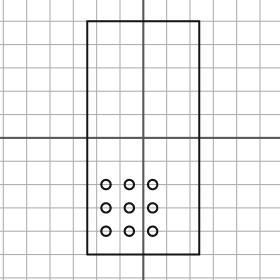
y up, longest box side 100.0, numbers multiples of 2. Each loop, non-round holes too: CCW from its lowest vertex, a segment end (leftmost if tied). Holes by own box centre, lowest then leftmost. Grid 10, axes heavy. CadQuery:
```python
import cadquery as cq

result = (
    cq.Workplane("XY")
    .moveTo(-24.0, -50.0)
    .lineTo(24.0, -50.0)
    .lineTo(24.0, 50.0)
    .lineTo(-24.0, 50.0)
    .close()
    .moveTo(-16.0, -40.0)
    .circle(2.0)
    .moveTo(-6.0, -40.0)
    .circle(2.0)
    .moveTo(4.0, -40.0)
    .circle(2.0)
    .moveTo(-16.0, -30.0)
    .circle(2.0)
    .moveTo(-6.0, -30.0)
    .circle(2.0)
    .moveTo(4.0, -30.0)
    .circle(2.0)
    .moveTo(-16.0, -20.0)
    .circle(2.0)
    .moveTo(-6.0, -20.0)
    .circle(2.0)
    .moveTo(4.0, -20.0)
    .circle(2.0)
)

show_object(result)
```